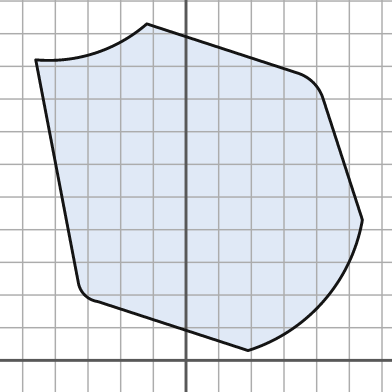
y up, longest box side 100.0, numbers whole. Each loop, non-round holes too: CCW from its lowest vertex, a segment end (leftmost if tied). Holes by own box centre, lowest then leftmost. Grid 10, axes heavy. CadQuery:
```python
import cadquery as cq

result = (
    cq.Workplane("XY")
    .moveTo(19.0, 3.0)
    .threePointArc((42.0, 18.0), (54.0, 43.0))
    .lineTo(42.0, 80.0)
    .threePointArc((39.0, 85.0), (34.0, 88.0))
    .lineTo(-12.0, 103.0)
    .threePointArc((-28.0, 94.0), (-46.0, 92.0))
    .lineTo(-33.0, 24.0)
    .threePointArc((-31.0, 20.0), (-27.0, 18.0))
    .close()
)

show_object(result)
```